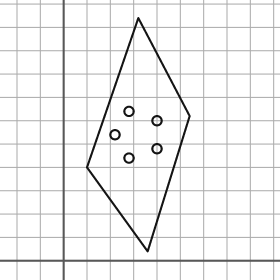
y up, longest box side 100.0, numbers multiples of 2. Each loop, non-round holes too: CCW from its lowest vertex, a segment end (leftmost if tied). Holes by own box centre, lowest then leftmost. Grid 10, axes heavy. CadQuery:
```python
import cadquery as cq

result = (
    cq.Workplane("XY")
    .moveTo(36.0, 4.0)
    .lineTo(54.0, 62.0)
    .lineTo(32.0, 104.0)
    .lineTo(10.0, 40.0)
    .close()
    .moveTo(28.0, 44.0)
    .circle(2.0)
    .moveTo(40.0, 48.0)
    .circle(2.0)
    .moveTo(22.0, 54.0)
    .circle(2.0)
    .moveTo(40.0, 60.0)
    .circle(2.0)
    .moveTo(28.0, 64.0)
    .circle(2.0)
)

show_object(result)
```